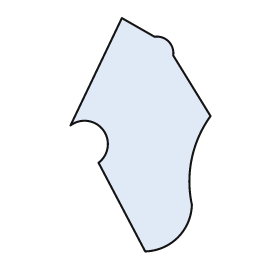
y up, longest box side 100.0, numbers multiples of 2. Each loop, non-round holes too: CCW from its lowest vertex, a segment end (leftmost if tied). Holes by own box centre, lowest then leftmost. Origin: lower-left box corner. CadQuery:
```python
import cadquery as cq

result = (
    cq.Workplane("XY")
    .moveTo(32.0, 0.0)
    .threePointArc((46.0, 6.0), (52.0, 20.0))
    .threePointArc((52.0, 40.0), (60.0, 58.0))
    .lineTo(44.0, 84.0)
    .threePointArc((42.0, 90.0), (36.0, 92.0))
    .lineTo(22.0, 100.0)
    .lineTo(0.0, 54.0)
    .threePointArc((14.0, 52.0), (12.0, 38.0))
    .close()
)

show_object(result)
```